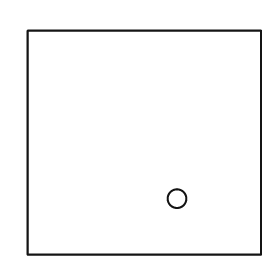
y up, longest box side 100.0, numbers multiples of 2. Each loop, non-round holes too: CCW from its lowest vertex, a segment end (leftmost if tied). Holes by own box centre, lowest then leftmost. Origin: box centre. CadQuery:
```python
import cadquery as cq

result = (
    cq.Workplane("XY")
    .moveTo(-50.0, -48.0)
    .lineTo(50.0, -48.0)
    .lineTo(50.0, 48.0)
    .lineTo(-50.0, 48.0)
    .close()
    .moveTo(14.0, -24.0)
    .circle(4.0)
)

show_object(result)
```